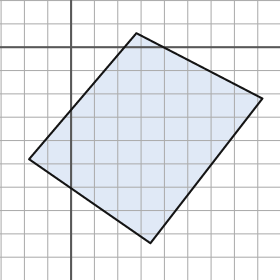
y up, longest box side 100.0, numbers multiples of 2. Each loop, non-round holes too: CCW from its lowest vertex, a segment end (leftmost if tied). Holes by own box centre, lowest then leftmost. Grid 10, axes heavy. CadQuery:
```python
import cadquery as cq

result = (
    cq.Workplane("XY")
    .moveTo(34.0, -84.0)
    .lineTo(82.0, -22.0)
    .lineTo(28.0, 6.0)
    .lineTo(-18.0, -48.0)
    .close()
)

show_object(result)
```